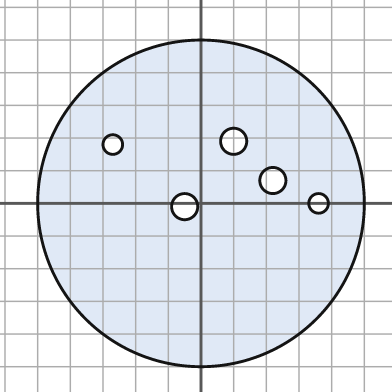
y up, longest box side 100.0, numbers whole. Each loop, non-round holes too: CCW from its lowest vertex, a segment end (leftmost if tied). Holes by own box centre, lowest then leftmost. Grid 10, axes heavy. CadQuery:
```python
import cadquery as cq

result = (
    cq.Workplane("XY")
    .moveTo(0.0, 0.0)
    .circle(50.0)
    .moveTo(-5.0, -1.0)
    .circle(4.0)
    .moveTo(36.0, 0.0)
    .circle(3.0)
    .moveTo(22.0, 7.0)
    .circle(4.0)
    .moveTo(-27.0, 18.0)
    .circle(3.0)
    .moveTo(10.0, 19.0)
    .circle(4.0)
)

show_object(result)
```